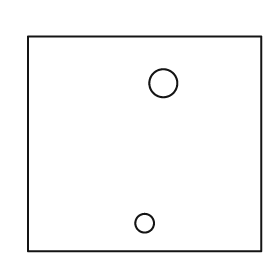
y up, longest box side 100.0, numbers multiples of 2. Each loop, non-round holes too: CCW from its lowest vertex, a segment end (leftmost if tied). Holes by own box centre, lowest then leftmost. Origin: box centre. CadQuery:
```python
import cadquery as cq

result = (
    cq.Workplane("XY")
    .moveTo(-50.0, -46.0)
    .lineTo(50.0, -46.0)
    .lineTo(50.0, 46.0)
    .lineTo(-50.0, 46.0)
    .close()
    .moveTo(0.0, -34.0)
    .circle(4.0)
    .moveTo(8.0, 26.0)
    .circle(6.0)
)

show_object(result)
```